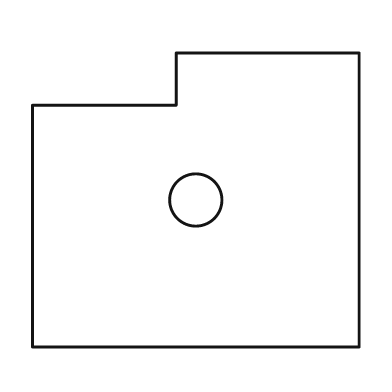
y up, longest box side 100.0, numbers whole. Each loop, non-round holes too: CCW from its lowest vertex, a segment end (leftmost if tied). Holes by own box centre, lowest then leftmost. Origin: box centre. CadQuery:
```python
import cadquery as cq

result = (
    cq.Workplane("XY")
    .moveTo(-50.0, -45.0)
    .lineTo(50.0, -45.0)
    .lineTo(50.0, 45.0)
    .lineTo(-6.0, 45.0)
    .lineTo(-6.0, 29.0)
    .lineTo(-50.0, 29.0)
    .close()
    .moveTo(0.0, 0.0)
    .circle(8.0)
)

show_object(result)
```